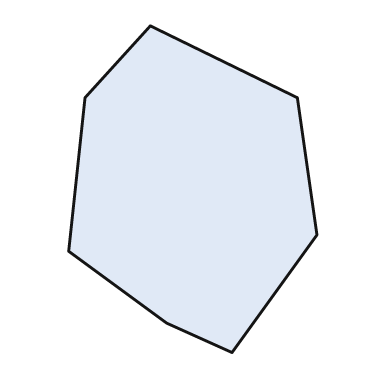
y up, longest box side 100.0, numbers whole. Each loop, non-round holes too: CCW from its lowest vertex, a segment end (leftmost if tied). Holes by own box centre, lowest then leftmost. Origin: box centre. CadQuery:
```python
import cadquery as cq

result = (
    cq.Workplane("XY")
    .moveTo(12.0, -50.0)
    .lineTo(38.0, -14.0)
    .lineTo(32.0, 28.0)
    .lineTo(-13.0, 50.0)
    .lineTo(-33.0, 28.0)
    .lineTo(-38.0, -19.0)
    .lineTo(-8.0, -41.0)
    .close()
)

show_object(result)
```